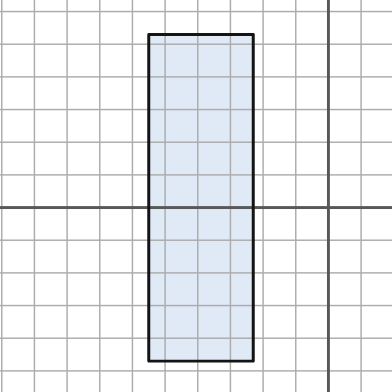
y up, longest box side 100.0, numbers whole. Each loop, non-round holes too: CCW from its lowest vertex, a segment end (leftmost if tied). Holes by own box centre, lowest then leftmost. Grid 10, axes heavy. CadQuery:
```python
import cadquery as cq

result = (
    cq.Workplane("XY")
    .moveTo(-55.0, -47.0)
    .lineTo(-23.0, -47.0)
    .lineTo(-23.0, 53.0)
    .lineTo(-55.0, 53.0)
    .close()
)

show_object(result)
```